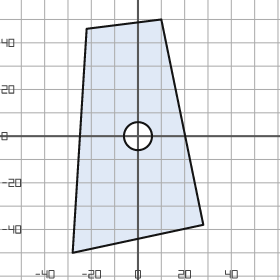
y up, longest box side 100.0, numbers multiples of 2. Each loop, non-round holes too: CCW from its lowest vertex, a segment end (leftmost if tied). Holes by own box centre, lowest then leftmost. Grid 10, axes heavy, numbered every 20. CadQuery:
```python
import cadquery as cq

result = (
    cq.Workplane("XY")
    .moveTo(-28.0, -50.0)
    .lineTo(28.0, -38.0)
    .lineTo(10.0, 50.0)
    .lineTo(-22.0, 46.0)
    .close()
    .moveTo(0.0, 0.0)
    .circle(6.0)
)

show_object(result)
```